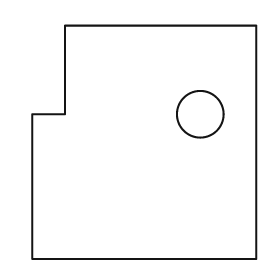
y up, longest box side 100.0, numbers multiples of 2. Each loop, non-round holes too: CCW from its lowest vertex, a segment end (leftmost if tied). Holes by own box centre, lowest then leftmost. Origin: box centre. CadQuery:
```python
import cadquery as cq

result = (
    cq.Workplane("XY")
    .moveTo(-48.0, -50.0)
    .lineTo(48.0, -50.0)
    .lineTo(48.0, 50.0)
    .lineTo(-34.0, 50.0)
    .lineTo(-34.0, 12.0)
    .lineTo(-48.0, 12.0)
    .close()
    .moveTo(24.0, 12.0)
    .circle(10.0)
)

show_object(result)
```